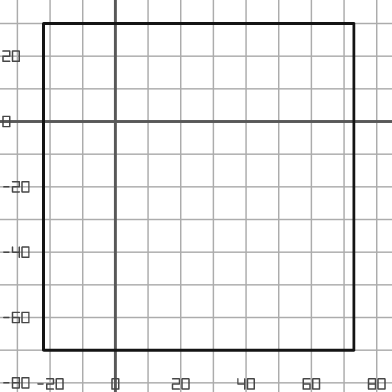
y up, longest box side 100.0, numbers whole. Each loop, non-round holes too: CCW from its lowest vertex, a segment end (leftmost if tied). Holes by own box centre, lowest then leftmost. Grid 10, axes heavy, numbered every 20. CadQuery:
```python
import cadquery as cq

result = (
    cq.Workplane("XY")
    .moveTo(-22.0, -70.0)
    .lineTo(73.0, -70.0)
    .lineTo(73.0, 30.0)
    .lineTo(-22.0, 30.0)
    .close()
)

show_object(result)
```